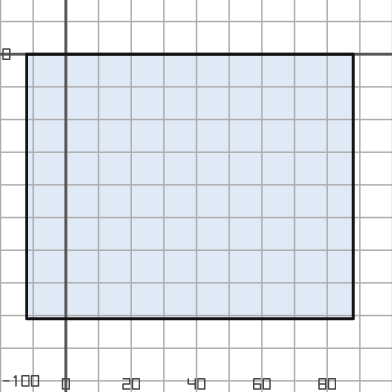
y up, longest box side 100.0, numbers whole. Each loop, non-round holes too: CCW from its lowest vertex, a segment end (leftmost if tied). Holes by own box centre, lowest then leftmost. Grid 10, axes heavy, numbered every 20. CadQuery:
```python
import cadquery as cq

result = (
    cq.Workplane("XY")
    .moveTo(-12.0, -81.0)
    .lineTo(88.0, -81.0)
    .lineTo(88.0, 0.0)
    .lineTo(-12.0, 0.0)
    .close()
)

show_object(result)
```